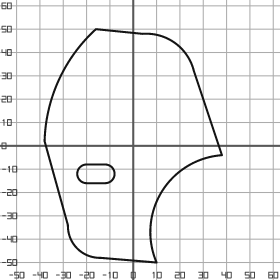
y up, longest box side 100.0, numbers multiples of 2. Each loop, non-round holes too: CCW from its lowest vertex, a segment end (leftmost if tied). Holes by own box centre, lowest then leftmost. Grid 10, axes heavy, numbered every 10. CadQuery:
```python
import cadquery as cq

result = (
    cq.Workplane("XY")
    .moveTo(10.0, -50.0)
    .threePointArc((12.0, -20.0), (38.0, -4.0))
    .lineTo(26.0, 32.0)
    .threePointArc((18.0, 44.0), (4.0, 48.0))
    .lineTo(-16.0, 50.0)
    .threePointArc((-32.0, 28.0), (-38.0, 2.0))
    .lineTo(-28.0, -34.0)
    .threePointArc((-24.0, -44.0), (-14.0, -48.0))
    .close()
    .moveTo(-20.0, -16.0)
    .lineTo(-12.0, -16.0)
    .threePointArc((-8.0, -12.0), (-12.0, -8.0))
    .lineTo(-20.0, -8.0)
    .threePointArc((-24.0, -12.0), (-20.0, -16.0))
    .close()
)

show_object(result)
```